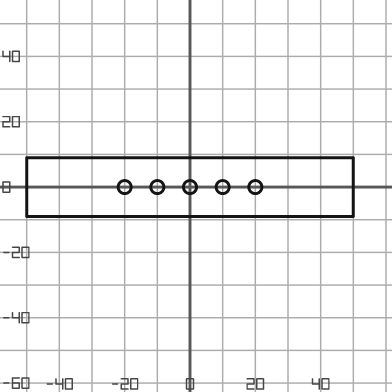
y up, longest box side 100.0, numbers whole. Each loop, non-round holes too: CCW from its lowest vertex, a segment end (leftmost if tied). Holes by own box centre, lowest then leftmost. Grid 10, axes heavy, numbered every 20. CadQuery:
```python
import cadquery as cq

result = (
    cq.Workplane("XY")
    .moveTo(-50.0, -9.0)
    .lineTo(50.0, -9.0)
    .lineTo(50.0, 9.0)
    .lineTo(-50.0, 9.0)
    .close()
    .moveTo(-20.0, 0.0)
    .circle(2.0)
    .moveTo(-10.0, 0.0)
    .circle(2.0)
    .moveTo(0.0, 0.0)
    .circle(2.0)
    .moveTo(10.0, 0.0)
    .circle(2.0)
    .moveTo(20.0, 0.0)
    .circle(2.0)
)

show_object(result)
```